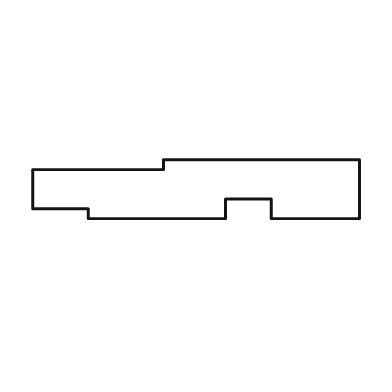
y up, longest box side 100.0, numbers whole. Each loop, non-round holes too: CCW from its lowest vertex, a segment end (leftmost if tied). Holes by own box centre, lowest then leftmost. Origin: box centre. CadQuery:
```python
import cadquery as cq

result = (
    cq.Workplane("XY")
    .moveTo(-33.0, -9.0)
    .lineTo(9.0, -9.0)
    .lineTo(9.0, -3.0)
    .lineTo(23.0, -3.0)
    .lineTo(23.0, -9.0)
    .lineTo(50.0, -9.0)
    .lineTo(50.0, 9.0)
    .lineTo(-10.0, 9.0)
    .lineTo(-10.0, 6.0)
    .lineTo(-50.0, 6.0)
    .lineTo(-50.0, -6.0)
    .lineTo(-33.0, -6.0)
    .close()
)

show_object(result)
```